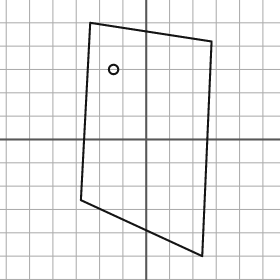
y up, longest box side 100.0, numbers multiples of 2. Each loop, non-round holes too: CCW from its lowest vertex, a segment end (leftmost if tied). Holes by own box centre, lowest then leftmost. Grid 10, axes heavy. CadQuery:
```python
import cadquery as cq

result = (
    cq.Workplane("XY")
    .moveTo(24.0, -50.0)
    .lineTo(28.0, 42.0)
    .lineTo(-24.0, 50.0)
    .lineTo(-28.0, -26.0)
    .close()
    .moveTo(-14.0, 30.0)
    .circle(2.0)
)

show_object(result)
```